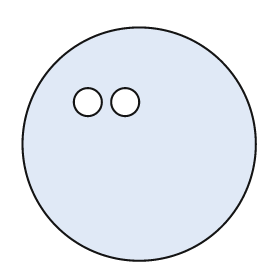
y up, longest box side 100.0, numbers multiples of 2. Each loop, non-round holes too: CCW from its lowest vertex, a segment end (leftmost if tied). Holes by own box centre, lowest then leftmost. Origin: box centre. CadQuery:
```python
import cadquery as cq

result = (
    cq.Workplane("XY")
    .moveTo(0.0, 0.0)
    .circle(50.0)
    .moveTo(-22.0, 18.0)
    .circle(6.0)
    .moveTo(-6.0, 18.0)
    .circle(6.0)
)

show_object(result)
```